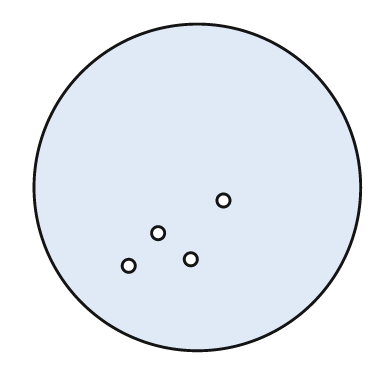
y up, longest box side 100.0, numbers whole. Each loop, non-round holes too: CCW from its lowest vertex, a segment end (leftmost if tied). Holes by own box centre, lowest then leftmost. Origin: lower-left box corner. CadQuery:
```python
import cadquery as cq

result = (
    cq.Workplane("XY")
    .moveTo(50.0, 50.0)
    .circle(50.0)
    .moveTo(29.0, 26.0)
    .circle(2.0)
    .moveTo(48.0, 28.0)
    .circle(2.0)
    .moveTo(38.0, 36.0)
    .circle(2.0)
    .moveTo(58.0, 46.0)
    .circle(2.0)
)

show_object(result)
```